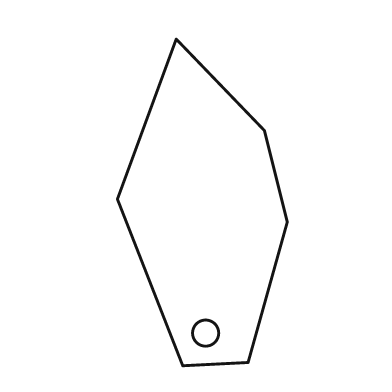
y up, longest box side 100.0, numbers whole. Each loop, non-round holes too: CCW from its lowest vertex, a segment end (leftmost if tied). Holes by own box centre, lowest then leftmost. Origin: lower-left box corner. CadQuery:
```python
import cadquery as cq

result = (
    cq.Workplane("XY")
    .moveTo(20.0, 0.0)
    .lineTo(40.0, 1.0)
    .lineTo(52.0, 44.0)
    .lineTo(45.0, 72.0)
    .lineTo(18.0, 100.0)
    .lineTo(0.0, 51.0)
    .close()
    .moveTo(27.0, 10.0)
    .circle(4.0)
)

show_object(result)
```